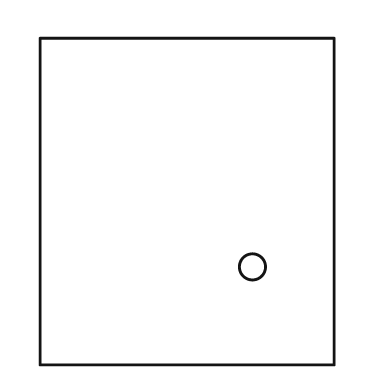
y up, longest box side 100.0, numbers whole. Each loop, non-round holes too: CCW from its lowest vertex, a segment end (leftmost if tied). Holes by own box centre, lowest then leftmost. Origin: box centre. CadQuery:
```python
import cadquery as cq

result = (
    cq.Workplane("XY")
    .moveTo(-45.0, -50.0)
    .lineTo(45.0, -50.0)
    .lineTo(45.0, 50.0)
    .lineTo(-45.0, 50.0)
    .close()
    .moveTo(20.0, -20.0)
    .circle(4.0)
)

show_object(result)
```